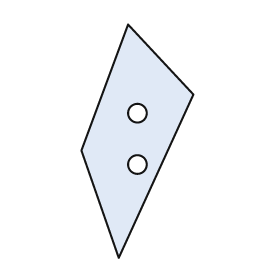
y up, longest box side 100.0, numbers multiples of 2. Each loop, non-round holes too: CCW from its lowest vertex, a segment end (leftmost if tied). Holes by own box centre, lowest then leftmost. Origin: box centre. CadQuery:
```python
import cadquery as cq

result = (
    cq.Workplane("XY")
    .moveTo(-8.0, -50.0)
    .lineTo(24.0, 20.0)
    .lineTo(-4.0, 50.0)
    .lineTo(-24.0, -4.0)
    .close()
    .moveTo(0.0, -10.0)
    .circle(4.0)
    .moveTo(0.0, 12.0)
    .circle(4.0)
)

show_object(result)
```